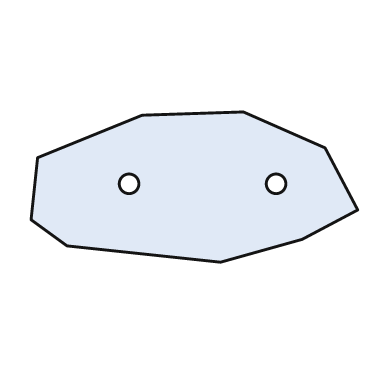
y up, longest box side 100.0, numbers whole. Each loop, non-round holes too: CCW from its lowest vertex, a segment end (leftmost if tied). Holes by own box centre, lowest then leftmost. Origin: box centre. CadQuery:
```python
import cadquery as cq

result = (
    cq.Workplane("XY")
    .moveTo(8.0, -23.0)
    .lineTo(33.0, -16.0)
    .lineTo(50.0, -7.0)
    .lineTo(40.0, 12.0)
    .lineTo(15.0, 23.0)
    .lineTo(-16.0, 22.0)
    .lineTo(-48.0, 9.0)
    .lineTo(-50.0, -10.0)
    .lineTo(-39.0, -18.0)
    .close()
    .moveTo(-20.0, 1.0)
    .circle(3.0)
    .moveTo(25.0, 1.0)
    .circle(3.0)
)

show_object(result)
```